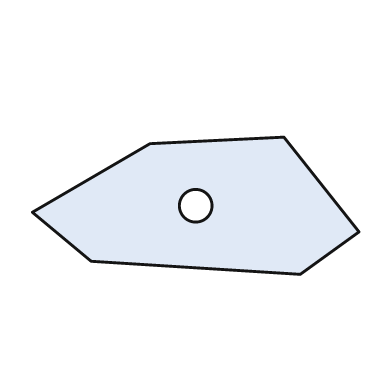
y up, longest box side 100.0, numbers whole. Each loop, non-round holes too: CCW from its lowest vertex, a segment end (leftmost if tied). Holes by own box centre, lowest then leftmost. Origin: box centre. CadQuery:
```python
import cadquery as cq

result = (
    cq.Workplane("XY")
    .moveTo(32.0, -21.0)
    .lineTo(50.0, -8.0)
    .lineTo(27.0, 21.0)
    .lineTo(-14.0, 19.0)
    .lineTo(-50.0, -2.0)
    .lineTo(-32.0, -17.0)
    .close()
    .moveTo(0.0, 0.0)
    .circle(5.0)
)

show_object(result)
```